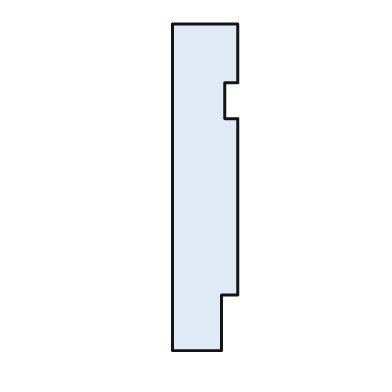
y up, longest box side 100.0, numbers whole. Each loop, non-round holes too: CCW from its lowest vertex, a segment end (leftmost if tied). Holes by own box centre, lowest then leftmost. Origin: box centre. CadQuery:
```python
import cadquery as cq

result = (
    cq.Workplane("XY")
    .moveTo(-10.0, -50.0)
    .lineTo(5.0, -50.0)
    .lineTo(5.0, -33.0)
    .lineTo(10.0, -33.0)
    .lineTo(10.0, 21.0)
    .lineTo(6.0, 21.0)
    .lineTo(6.0, 32.0)
    .lineTo(10.0, 32.0)
    .lineTo(10.0, 50.0)
    .lineTo(-10.0, 50.0)
    .close()
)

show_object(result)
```